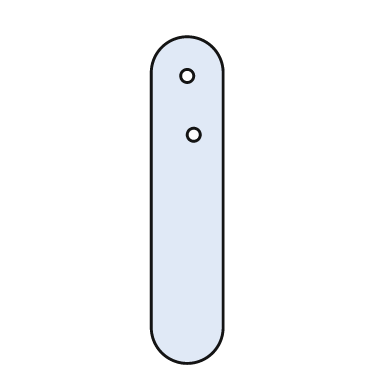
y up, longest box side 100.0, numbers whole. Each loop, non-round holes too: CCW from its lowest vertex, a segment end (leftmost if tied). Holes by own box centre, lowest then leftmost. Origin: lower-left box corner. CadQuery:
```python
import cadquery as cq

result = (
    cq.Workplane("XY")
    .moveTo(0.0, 11.0)
    .threePointArc((11.0, 0.0), (22.0, 11.0))
    .lineTo(22.0, 89.0)
    .threePointArc((11.0, 100.0), (0.0, 89.0))
    .close()
    .moveTo(13.0, 70.0)
    .circle(2.0)
    .moveTo(11.0, 88.0)
    .circle(2.0)
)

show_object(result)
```